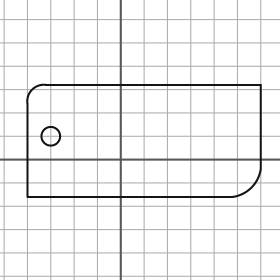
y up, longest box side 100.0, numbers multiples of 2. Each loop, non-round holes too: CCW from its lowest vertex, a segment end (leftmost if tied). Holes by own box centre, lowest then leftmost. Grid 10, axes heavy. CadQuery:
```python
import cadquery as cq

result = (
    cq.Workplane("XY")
    .moveTo(-40.0, -16.0)
    .lineTo(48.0, -16.0)
    .threePointArc((56.0, -12.0), (60.0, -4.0))
    .lineTo(60.0, 32.0)
    .lineTo(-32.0, 32.0)
    .threePointArc((-38.0, 30.0), (-40.0, 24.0))
    .close()
    .moveTo(-30.0, 10.0)
    .circle(4.0)
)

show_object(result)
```